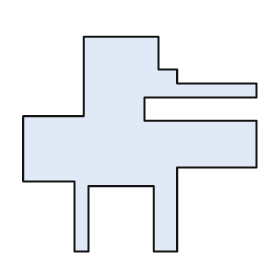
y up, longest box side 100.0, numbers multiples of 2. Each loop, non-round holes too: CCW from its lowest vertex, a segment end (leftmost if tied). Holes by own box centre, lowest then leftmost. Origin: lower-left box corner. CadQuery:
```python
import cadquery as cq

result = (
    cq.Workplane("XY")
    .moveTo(22.0, 0.0)
    .lineTo(28.0, 0.0)
    .lineTo(28.0, 28.0)
    .lineTo(56.0, 28.0)
    .lineTo(56.0, 0.0)
    .lineTo(66.0, 0.0)
    .lineTo(66.0, 36.0)
    .lineTo(100.0, 36.0)
    .lineTo(100.0, 56.0)
    .lineTo(52.0, 56.0)
    .lineTo(52.0, 66.0)
    .lineTo(100.0, 66.0)
    .lineTo(100.0, 72.0)
    .lineTo(66.0, 72.0)
    .lineTo(66.0, 78.0)
    .lineTo(58.0, 78.0)
    .lineTo(58.0, 92.0)
    .lineTo(26.0, 92.0)
    .lineTo(26.0, 58.0)
    .lineTo(0.0, 58.0)
    .lineTo(0.0, 30.0)
    .lineTo(22.0, 30.0)
    .close()
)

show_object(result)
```